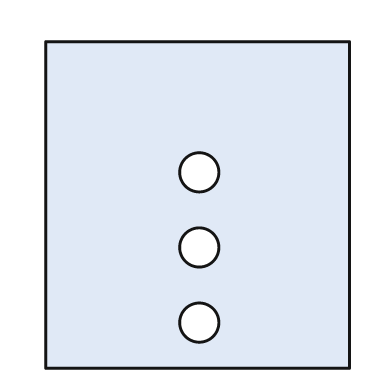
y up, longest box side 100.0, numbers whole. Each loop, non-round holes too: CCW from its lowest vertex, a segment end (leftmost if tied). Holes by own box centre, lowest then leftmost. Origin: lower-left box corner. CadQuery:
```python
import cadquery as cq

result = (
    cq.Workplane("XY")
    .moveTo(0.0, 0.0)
    .lineTo(93.0, 0.0)
    .lineTo(93.0, 100.0)
    .lineTo(0.0, 100.0)
    .close()
    .moveTo(47.0, 14.0)
    .circle(6.0)
    .moveTo(47.0, 37.0)
    .circle(6.0)
    .moveTo(47.0, 60.0)
    .circle(6.0)
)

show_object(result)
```